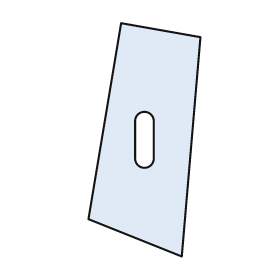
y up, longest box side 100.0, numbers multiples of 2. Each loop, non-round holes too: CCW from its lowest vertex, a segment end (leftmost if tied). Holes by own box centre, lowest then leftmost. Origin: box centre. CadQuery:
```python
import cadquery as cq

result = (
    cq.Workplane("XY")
    .moveTo(16.0, -50.0)
    .lineTo(24.0, 44.0)
    .lineTo(-10.0, 50.0)
    .lineTo(-24.0, -34.0)
    .close()
    .moveTo(-4.0, -8.0)
    .threePointArc((0.0, -12.0), (4.0, -8.0))
    .lineTo(4.0, 8.0)
    .threePointArc((0.0, 12.0), (-4.0, 8.0))
    .close()
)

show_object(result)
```